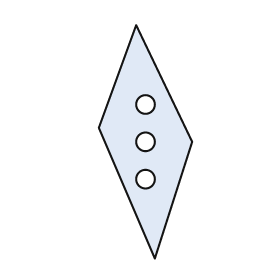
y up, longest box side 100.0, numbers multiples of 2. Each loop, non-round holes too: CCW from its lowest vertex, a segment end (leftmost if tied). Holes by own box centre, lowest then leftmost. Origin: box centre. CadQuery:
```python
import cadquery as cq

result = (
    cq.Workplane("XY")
    .moveTo(4.0, -50.0)
    .lineTo(20.0, 0.0)
    .lineTo(-4.0, 50.0)
    .lineTo(-20.0, 6.0)
    .close()
    .moveTo(0.0, -16.0)
    .circle(4.0)
    .moveTo(0.0, 0.0)
    .circle(4.0)
    .moveTo(0.0, 16.0)
    .circle(4.0)
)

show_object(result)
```